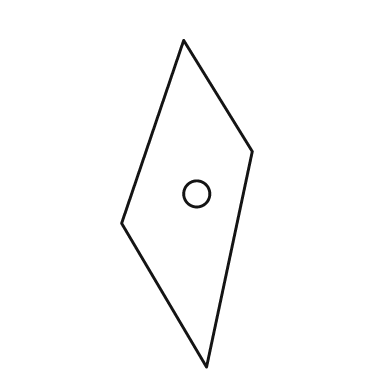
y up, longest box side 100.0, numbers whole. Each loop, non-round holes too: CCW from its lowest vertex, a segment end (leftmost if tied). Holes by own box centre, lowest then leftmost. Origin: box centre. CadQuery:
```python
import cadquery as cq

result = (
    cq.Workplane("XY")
    .moveTo(6.0, -50.0)
    .lineTo(20.0, 16.0)
    .lineTo(-1.0, 50.0)
    .lineTo(-20.0, -6.0)
    .close()
    .moveTo(3.0, 3.0)
    .circle(4.0)
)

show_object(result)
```